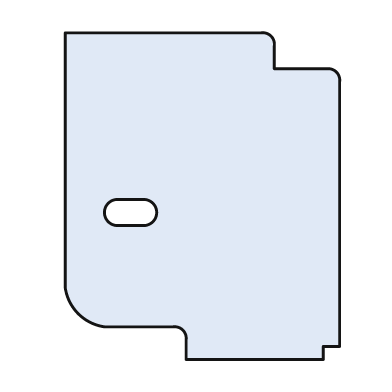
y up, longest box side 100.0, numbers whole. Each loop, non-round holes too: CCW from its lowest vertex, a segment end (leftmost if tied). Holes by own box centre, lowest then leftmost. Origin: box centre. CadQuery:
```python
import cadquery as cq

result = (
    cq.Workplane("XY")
    .moveTo(-5.0, -50.0)
    .lineTo(37.0, -50.0)
    .lineTo(37.0, -46.0)
    .lineTo(42.0, -46.0)
    .lineTo(42.0, 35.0)
    .threePointArc((41.0, 38.0), (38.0, 39.0))
    .lineTo(22.0, 39.0)
    .lineTo(22.0, 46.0)
    .threePointArc((21.0, 49.0), (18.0, 50.0))
    .lineTo(-42.0, 50.0)
    .lineTo(-42.0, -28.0)
    .threePointArc((-38.0, -36.0), (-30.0, -40.0))
    .lineTo(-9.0, -40.0)
    .threePointArc((-6.0, -41.0), (-5.0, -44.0))
    .close()
    .moveTo(-26.0, -9.0)
    .lineTo(-18.0, -9.0)
    .threePointArc((-14.0, -5.0), (-18.0, -1.0))
    .lineTo(-26.0, -1.0)
    .threePointArc((-30.0, -5.0), (-26.0, -9.0))
    .close()
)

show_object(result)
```